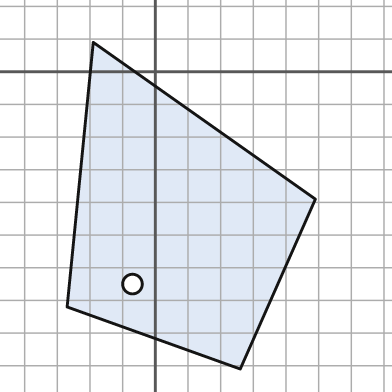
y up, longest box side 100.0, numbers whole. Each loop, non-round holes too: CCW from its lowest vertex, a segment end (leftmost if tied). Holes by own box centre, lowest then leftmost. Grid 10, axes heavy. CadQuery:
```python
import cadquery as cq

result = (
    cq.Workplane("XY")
    .moveTo(26.0, -91.0)
    .lineTo(49.0, -39.0)
    .lineTo(-19.0, 9.0)
    .lineTo(-27.0, -72.0)
    .close()
    .moveTo(-7.0, -65.0)
    .circle(3.0)
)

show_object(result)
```